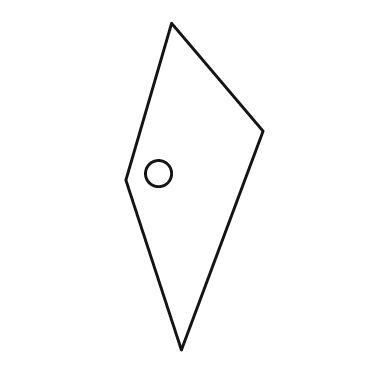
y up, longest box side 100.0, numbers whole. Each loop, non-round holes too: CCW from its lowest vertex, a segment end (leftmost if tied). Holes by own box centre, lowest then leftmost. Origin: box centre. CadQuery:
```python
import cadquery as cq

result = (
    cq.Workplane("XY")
    .moveTo(-4.0, -50.0)
    .lineTo(21.0, 17.0)
    .lineTo(-7.0, 50.0)
    .lineTo(-21.0, 2.0)
    .close()
    .moveTo(-11.0, 4.0)
    .circle(4.0)
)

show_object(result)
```